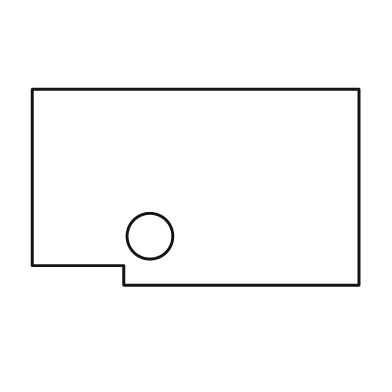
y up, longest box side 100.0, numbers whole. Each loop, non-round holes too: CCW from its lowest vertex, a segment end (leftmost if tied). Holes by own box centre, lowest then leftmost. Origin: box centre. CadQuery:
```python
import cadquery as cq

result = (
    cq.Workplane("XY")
    .moveTo(-22.0, -30.0)
    .lineTo(50.0, -30.0)
    .lineTo(50.0, 30.0)
    .lineTo(-50.0, 30.0)
    .lineTo(-50.0, -24.0)
    .lineTo(-22.0, -24.0)
    .close()
    .moveTo(-14.0, -15.0)
    .circle(7.0)
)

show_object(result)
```